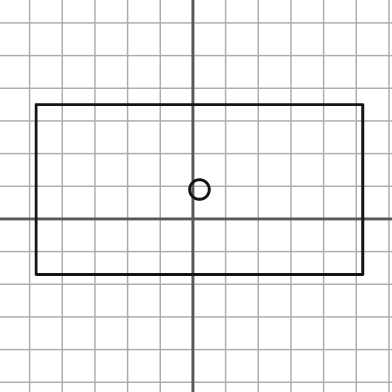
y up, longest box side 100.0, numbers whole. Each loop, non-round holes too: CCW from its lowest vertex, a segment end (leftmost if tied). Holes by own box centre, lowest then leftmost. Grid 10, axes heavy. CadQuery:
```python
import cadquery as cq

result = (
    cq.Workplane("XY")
    .moveTo(-48.0, -17.0)
    .lineTo(52.0, -17.0)
    .lineTo(52.0, 35.0)
    .lineTo(-48.0, 35.0)
    .close()
    .moveTo(2.0, 9.0)
    .circle(3.0)
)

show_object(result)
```